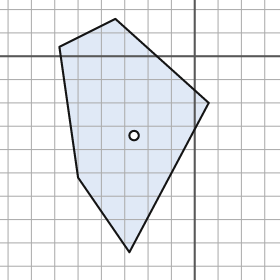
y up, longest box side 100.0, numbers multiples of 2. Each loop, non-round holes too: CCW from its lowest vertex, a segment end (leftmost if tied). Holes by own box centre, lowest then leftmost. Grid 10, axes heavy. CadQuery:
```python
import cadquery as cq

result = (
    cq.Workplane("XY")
    .moveTo(-28.0, -84.0)
    .lineTo(6.0, -20.0)
    .lineTo(-34.0, 16.0)
    .lineTo(-58.0, 4.0)
    .lineTo(-50.0, -52.0)
    .close()
    .moveTo(-26.0, -34.0)
    .circle(2.0)
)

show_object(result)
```